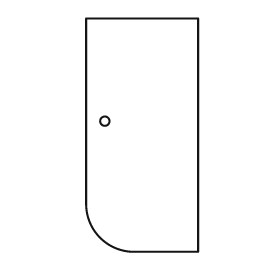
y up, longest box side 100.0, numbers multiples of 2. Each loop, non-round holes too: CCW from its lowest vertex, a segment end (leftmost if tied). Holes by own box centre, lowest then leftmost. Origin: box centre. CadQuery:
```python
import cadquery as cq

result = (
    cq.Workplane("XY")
    .moveTo(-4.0, -50.0)
    .lineTo(24.0, -50.0)
    .lineTo(24.0, 50.0)
    .lineTo(-24.0, 50.0)
    .lineTo(-24.0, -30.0)
    .threePointArc((-18.0, -44.0), (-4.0, -50.0))
    .close()
    .moveTo(-16.0, 6.0)
    .circle(2.0)
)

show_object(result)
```